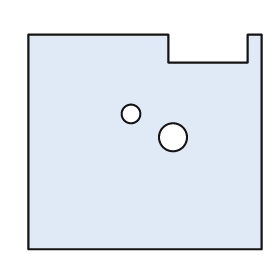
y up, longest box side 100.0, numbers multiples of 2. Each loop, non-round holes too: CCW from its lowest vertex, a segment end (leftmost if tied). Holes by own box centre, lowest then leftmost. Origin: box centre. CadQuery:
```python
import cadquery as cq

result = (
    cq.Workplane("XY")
    .moveTo(-50.0, -46.0)
    .lineTo(50.0, -46.0)
    .lineTo(50.0, 46.0)
    .lineTo(44.0, 46.0)
    .lineTo(44.0, 34.0)
    .lineTo(10.0, 34.0)
    .lineTo(10.0, 46.0)
    .lineTo(-50.0, 46.0)
    .close()
    .moveTo(12.0, 2.0)
    .circle(6.0)
    .moveTo(-6.0, 12.0)
    .circle(4.0)
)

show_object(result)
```